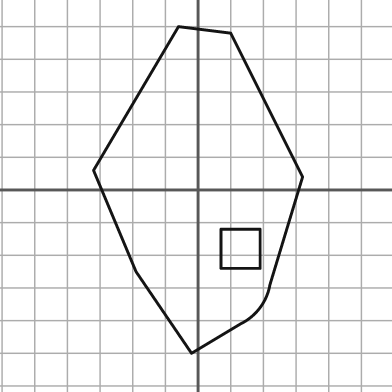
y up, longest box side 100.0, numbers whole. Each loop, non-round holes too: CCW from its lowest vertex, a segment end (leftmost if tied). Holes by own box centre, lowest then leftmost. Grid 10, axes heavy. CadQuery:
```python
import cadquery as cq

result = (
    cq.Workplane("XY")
    .moveTo(-2.0, -50.0)
    .lineTo(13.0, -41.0)
    .threePointArc((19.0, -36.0), (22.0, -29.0))
    .lineTo(32.0, 4.0)
    .lineTo(10.0, 48.0)
    .lineTo(-6.0, 50.0)
    .lineTo(-32.0, 6.0)
    .lineTo(-19.0, -25.0)
    .close()
    .moveTo(7.0, -24.0)
    .lineTo(19.0, -24.0)
    .lineTo(19.0, -12.0)
    .lineTo(7.0, -12.0)
    .close()
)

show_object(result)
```